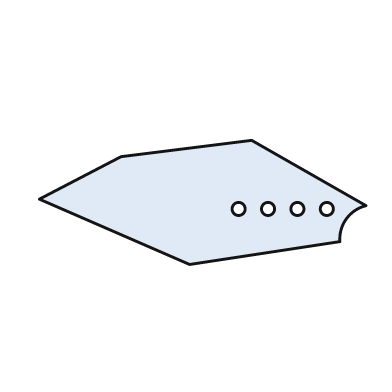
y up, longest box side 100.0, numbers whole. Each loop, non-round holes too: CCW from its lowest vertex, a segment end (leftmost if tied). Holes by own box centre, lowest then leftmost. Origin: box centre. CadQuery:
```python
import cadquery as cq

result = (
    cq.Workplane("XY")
    .moveTo(-4.0, -19.0)
    .lineTo(42.0, -12.0)
    .threePointArc((44.0, -5.0), (50.0, -1.0))
    .lineTo(15.0, 19.0)
    .lineTo(-25.0, 14.0)
    .lineTo(-50.0, 1.0)
    .close()
    .moveTo(11.0, -2.0)
    .circle(2.0)
    .moveTo(20.0, -2.0)
    .circle(2.0)
    .moveTo(29.0, -2.0)
    .circle(2.0)
    .moveTo(38.0, -2.0)
    .circle(2.0)
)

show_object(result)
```